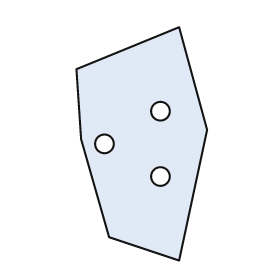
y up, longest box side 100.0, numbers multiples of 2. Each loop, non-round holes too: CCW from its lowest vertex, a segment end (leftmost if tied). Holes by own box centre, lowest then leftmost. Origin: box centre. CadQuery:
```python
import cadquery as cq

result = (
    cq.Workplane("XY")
    .moveTo(16.0, -50.0)
    .lineTo(28.0, 6.0)
    .lineTo(16.0, 50.0)
    .lineTo(-28.0, 32.0)
    .lineTo(-26.0, 2.0)
    .lineTo(-14.0, -40.0)
    .close()
    .moveTo(8.0, -14.0)
    .circle(4.0)
    .moveTo(-16.0, 0.0)
    .circle(4.0)
    .moveTo(8.0, 14.0)
    .circle(4.0)
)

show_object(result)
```